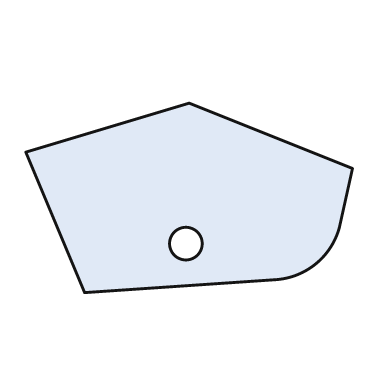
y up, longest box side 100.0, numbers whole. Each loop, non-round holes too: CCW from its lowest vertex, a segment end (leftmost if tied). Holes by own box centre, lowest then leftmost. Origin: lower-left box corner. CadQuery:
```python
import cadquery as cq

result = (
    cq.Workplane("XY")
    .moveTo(18.0, 0.0)
    .lineTo(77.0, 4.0)
    .threePointArc((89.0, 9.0), (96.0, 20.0))
    .lineTo(100.0, 38.0)
    .lineTo(50.0, 58.0)
    .lineTo(0.0, 43.0)
    .close()
    .moveTo(49.0, 15.0)
    .circle(5.0)
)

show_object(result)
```